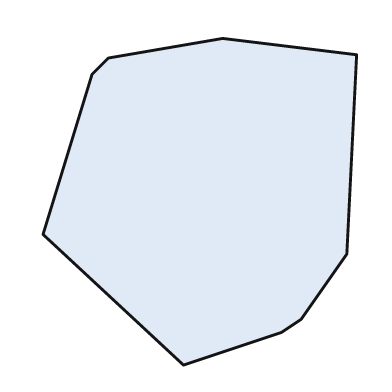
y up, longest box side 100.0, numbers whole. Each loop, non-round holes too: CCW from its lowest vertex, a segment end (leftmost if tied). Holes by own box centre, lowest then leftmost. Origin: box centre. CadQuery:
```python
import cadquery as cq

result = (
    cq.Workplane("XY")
    .moveTo(-5.0, -50.0)
    .lineTo(25.0, -40.0)
    .lineTo(31.0, -36.0)
    .lineTo(45.0, -16.0)
    .lineTo(48.0, 45.0)
    .lineTo(7.0, 50.0)
    .lineTo(-28.0, 44.0)
    .lineTo(-33.0, 39.0)
    .lineTo(-48.0, -10.0)
    .close()
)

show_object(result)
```